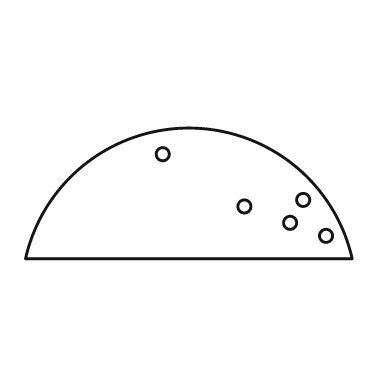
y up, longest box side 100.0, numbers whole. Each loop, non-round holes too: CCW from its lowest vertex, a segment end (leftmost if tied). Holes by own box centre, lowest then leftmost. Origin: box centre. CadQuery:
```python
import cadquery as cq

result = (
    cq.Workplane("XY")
    .moveTo(-50.0, -20.0)
    .lineTo(50.0, -20.0)
    .threePointArc((0.0, 20.0), (-50.0, -20.0))
    .close()
    .moveTo(42.0, -13.0)
    .circle(2.0)
    .moveTo(31.0, -9.0)
    .circle(2.0)
    .moveTo(17.0, -4.0)
    .circle(2.0)
    .moveTo(35.0, -2.0)
    .circle(2.0)
    .moveTo(-8.0, 12.0)
    .circle(2.0)
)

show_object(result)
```